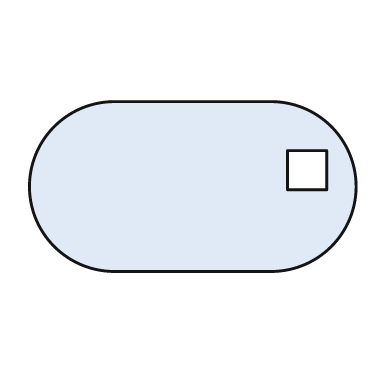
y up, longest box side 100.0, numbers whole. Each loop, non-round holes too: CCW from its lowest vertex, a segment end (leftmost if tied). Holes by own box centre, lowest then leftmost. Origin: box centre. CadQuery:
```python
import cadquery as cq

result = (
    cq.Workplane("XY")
    .moveTo(-24.0, -26.0)
    .lineTo(24.0, -26.0)
    .threePointArc((50.0, 0.0), (24.0, 26.0))
    .lineTo(-24.0, 26.0)
    .threePointArc((-50.0, 0.0), (-24.0, -26.0))
    .close()
    .moveTo(29.0, -1.0)
    .lineTo(41.0, -1.0)
    .lineTo(41.0, 11.0)
    .lineTo(29.0, 11.0)
    .close()
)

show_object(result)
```